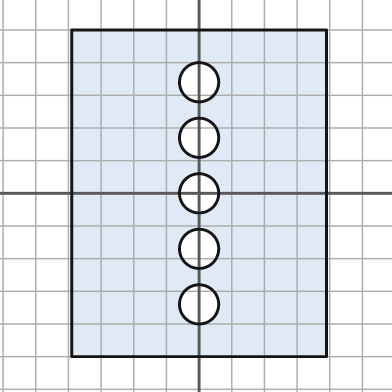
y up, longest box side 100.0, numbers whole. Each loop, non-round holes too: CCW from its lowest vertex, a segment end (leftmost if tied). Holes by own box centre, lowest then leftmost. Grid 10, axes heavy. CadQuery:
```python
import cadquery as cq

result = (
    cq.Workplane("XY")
    .moveTo(-39.0, -50.0)
    .lineTo(39.0, -50.0)
    .lineTo(39.0, 50.0)
    .lineTo(-39.0, 50.0)
    .close()
    .moveTo(0.0, -34.0)
    .circle(6.0)
    .moveTo(0.0, -17.0)
    .circle(6.0)
    .moveTo(0.0, 0.0)
    .circle(6.0)
    .moveTo(0.0, 17.0)
    .circle(6.0)
    .moveTo(0.0, 34.0)
    .circle(6.0)
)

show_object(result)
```